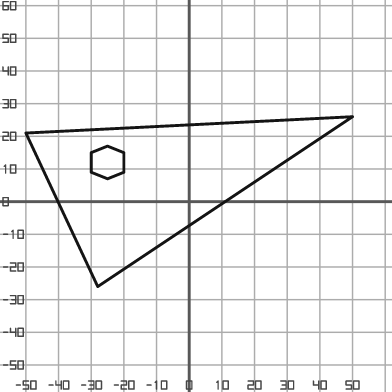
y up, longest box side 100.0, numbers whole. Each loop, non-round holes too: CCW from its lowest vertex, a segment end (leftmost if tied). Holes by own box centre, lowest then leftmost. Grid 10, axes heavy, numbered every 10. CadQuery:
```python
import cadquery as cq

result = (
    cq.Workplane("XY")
    .moveTo(-28.0, -26.0)
    .lineTo(50.0, 26.0)
    .lineTo(-50.0, 21.0)
    .close()
    .moveTo(-25.0, 7.0)
    .lineTo(-20.0, 9.0)
    .lineTo(-20.0, 15.0)
    .lineTo(-25.0, 17.0)
    .lineTo(-30.0, 15.0)
    .lineTo(-30.0, 9.0)
    .close()
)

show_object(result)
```